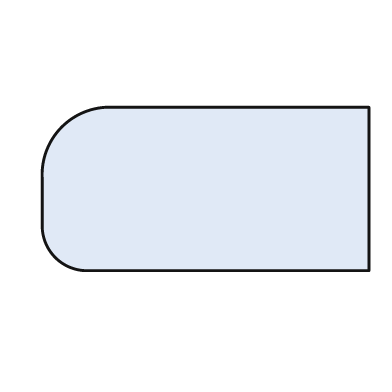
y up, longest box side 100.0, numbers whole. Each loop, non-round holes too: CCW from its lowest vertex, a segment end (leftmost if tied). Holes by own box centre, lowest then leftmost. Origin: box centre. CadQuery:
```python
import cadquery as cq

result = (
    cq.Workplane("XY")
    .moveTo(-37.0, -25.0)
    .lineTo(50.0, -25.0)
    .lineTo(50.0, 25.0)
    .lineTo(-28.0, 25.0)
    .threePointArc((-44.0, 19.0), (-50.0, 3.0))
    .lineTo(-50.0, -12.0)
    .threePointArc((-46.0, -21.0), (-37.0, -25.0))
    .close()
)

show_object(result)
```